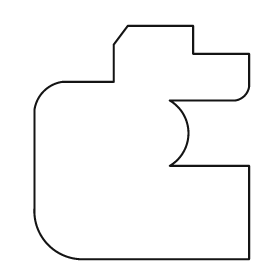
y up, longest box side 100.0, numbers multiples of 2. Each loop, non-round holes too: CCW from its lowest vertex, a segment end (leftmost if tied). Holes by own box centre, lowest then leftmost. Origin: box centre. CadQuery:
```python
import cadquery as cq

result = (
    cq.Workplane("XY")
    .moveTo(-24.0, -50.0)
    .lineTo(46.0, -50.0)
    .lineTo(46.0, -10.0)
    .lineTo(12.0, -10.0)
    .threePointArc((20.0, 4.0), (12.0, 18.0))
    .lineTo(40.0, 18.0)
    .threePointArc((44.0, 20.0), (46.0, 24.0))
    .lineTo(46.0, 38.0)
    .lineTo(22.0, 38.0)
    .lineTo(22.0, 50.0)
    .lineTo(-6.0, 50.0)
    .lineTo(-12.0, 42.0)
    .lineTo(-12.0, 26.0)
    .lineTo(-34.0, 26.0)
    .threePointArc((-42.0, 22.0), (-46.0, 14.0))
    .lineTo(-46.0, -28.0)
    .threePointArc((-40.0, -44.0), (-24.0, -50.0))
    .close()
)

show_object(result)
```